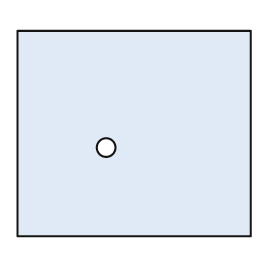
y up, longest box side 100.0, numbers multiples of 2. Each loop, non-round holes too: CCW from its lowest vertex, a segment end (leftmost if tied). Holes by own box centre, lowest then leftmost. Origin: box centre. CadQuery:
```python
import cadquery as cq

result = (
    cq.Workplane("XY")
    .moveTo(-50.0, -44.0)
    .lineTo(50.0, -44.0)
    .lineTo(50.0, 44.0)
    .lineTo(-50.0, 44.0)
    .close()
    .moveTo(-12.0, -6.0)
    .circle(4.0)
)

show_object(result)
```